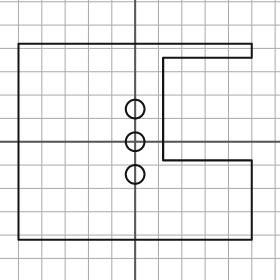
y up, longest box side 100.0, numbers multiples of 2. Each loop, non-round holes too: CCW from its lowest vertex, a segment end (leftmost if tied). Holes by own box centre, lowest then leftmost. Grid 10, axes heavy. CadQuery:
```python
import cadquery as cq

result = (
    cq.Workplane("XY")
    .moveTo(-50.0, -42.0)
    .lineTo(50.0, -42.0)
    .lineTo(50.0, -8.0)
    .lineTo(12.0, -8.0)
    .lineTo(12.0, 36.0)
    .lineTo(50.0, 36.0)
    .lineTo(50.0, 42.0)
    .lineTo(-50.0, 42.0)
    .close()
    .moveTo(0.0, -14.0)
    .circle(4.0)
    .moveTo(0.0, 0.0)
    .circle(4.0)
    .moveTo(0.0, 14.0)
    .circle(4.0)
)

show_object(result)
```